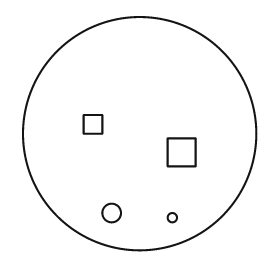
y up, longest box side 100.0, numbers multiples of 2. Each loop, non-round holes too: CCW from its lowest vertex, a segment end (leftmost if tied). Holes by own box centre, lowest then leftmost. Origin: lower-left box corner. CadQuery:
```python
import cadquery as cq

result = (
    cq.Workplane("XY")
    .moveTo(50.0, 50.0)
    .circle(50.0)
    .moveTo(64.0, 14.0)
    .circle(2.0)
    .moveTo(38.0, 16.0)
    .circle(4.0)
    .moveTo(62.0, 36.0)
    .lineTo(74.0, 36.0)
    .lineTo(74.0, 48.0)
    .lineTo(62.0, 48.0)
    .close()
    .moveTo(26.0, 50.0)
    .lineTo(34.0, 50.0)
    .lineTo(34.0, 58.0)
    .lineTo(26.0, 58.0)
    .close()
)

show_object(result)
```